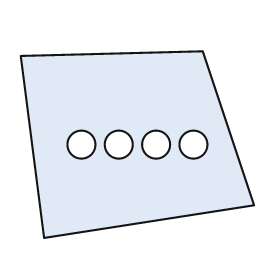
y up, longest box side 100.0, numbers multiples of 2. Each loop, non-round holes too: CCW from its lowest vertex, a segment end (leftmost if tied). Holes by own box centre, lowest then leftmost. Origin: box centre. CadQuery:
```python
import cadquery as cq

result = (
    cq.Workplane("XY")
    .moveTo(-40.0, -40.0)
    .lineTo(50.0, -26.0)
    .lineTo(28.0, 40.0)
    .lineTo(-50.0, 38.0)
    .close()
    .moveTo(-24.0, 0.0)
    .circle(6.0)
    .moveTo(-8.0, 0.0)
    .circle(6.0)
    .moveTo(8.0, 0.0)
    .circle(6.0)
    .moveTo(24.0, 0.0)
    .circle(6.0)
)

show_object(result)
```